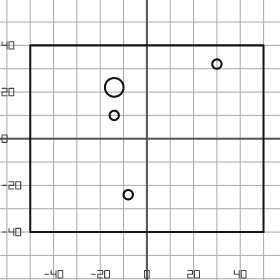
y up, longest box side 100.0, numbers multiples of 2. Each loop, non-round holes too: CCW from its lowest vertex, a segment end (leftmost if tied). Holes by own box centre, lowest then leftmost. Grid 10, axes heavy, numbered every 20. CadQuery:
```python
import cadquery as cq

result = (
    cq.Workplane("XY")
    .moveTo(-50.0, -40.0)
    .lineTo(50.0, -40.0)
    .lineTo(50.0, 40.0)
    .lineTo(-50.0, 40.0)
    .close()
    .moveTo(-8.0, -24.0)
    .circle(2.0)
    .moveTo(-14.0, 10.0)
    .circle(2.0)
    .moveTo(-14.0, 22.0)
    .circle(4.0)
    .moveTo(30.0, 32.0)
    .circle(2.0)
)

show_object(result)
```